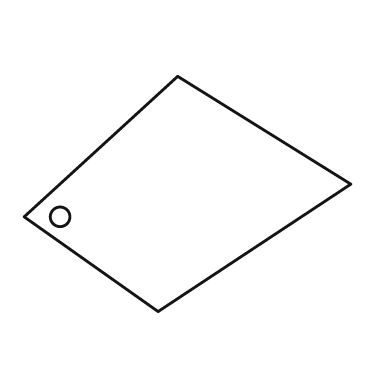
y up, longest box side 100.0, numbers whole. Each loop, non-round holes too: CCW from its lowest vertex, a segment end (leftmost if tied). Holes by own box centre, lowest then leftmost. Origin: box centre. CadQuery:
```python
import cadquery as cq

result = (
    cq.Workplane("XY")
    .moveTo(-9.0, -36.0)
    .lineTo(50.0, 3.0)
    .lineTo(-3.0, 36.0)
    .lineTo(-50.0, -7.0)
    .close()
    .moveTo(-39.0, -7.0)
    .circle(3.0)
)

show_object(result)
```